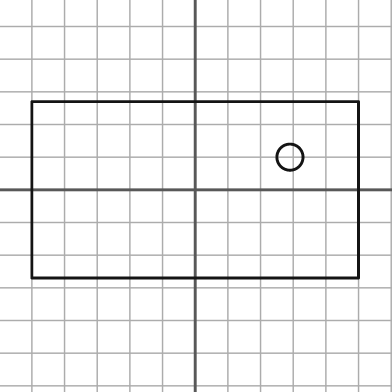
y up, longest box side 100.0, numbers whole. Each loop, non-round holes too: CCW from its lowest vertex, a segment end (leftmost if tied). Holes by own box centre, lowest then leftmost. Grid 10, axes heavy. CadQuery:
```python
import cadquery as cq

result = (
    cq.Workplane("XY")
    .moveTo(-50.0, -27.0)
    .lineTo(50.0, -27.0)
    .lineTo(50.0, 27.0)
    .lineTo(-50.0, 27.0)
    .close()
    .moveTo(29.0, 10.0)
    .circle(4.0)
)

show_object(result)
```